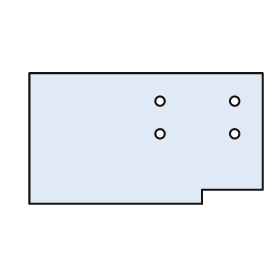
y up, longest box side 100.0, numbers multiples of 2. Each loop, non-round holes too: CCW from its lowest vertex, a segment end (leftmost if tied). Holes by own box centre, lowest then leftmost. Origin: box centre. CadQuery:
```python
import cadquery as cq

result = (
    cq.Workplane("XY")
    .moveTo(-50.0, -28.0)
    .lineTo(24.0, -28.0)
    .lineTo(24.0, -22.0)
    .lineTo(50.0, -22.0)
    .lineTo(50.0, 28.0)
    .lineTo(-50.0, 28.0)
    .close()
    .moveTo(6.0, 2.0)
    .circle(2.0)
    .moveTo(38.0, 2.0)
    .circle(2.0)
    .moveTo(6.0, 16.0)
    .circle(2.0)
    .moveTo(38.0, 16.0)
    .circle(2.0)
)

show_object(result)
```